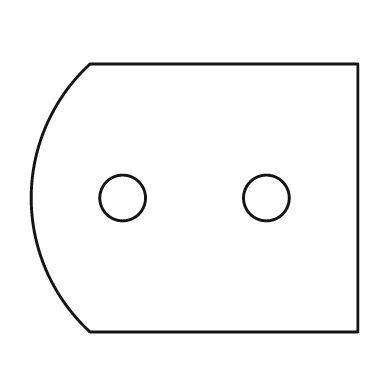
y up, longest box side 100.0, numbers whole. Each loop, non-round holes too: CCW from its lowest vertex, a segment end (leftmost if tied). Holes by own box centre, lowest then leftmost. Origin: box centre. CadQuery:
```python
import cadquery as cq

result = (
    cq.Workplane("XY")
    .moveTo(-32.0, -41.0)
    .lineTo(50.0, -41.0)
    .lineTo(50.0, 41.0)
    .lineTo(-32.0, 41.0)
    .threePointArc((-50.0, 0.0), (-32.0, -41.0))
    .close()
    .moveTo(-22.0, 0.0)
    .circle(7.0)
    .moveTo(22.0, 0.0)
    .circle(7.0)
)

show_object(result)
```